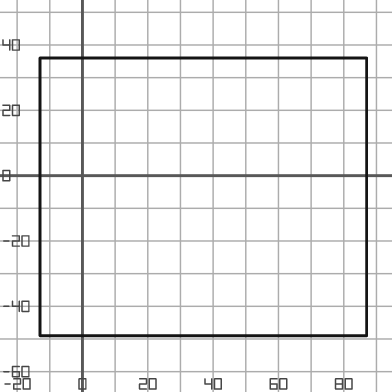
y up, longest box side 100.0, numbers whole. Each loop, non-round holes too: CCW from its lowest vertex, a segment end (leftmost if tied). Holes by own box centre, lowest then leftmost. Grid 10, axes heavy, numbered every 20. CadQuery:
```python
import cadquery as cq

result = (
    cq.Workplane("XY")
    .moveTo(-13.0, -49.0)
    .lineTo(87.0, -49.0)
    .lineTo(87.0, 36.0)
    .lineTo(-13.0, 36.0)
    .close()
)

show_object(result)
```